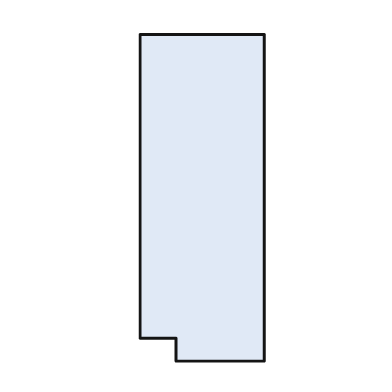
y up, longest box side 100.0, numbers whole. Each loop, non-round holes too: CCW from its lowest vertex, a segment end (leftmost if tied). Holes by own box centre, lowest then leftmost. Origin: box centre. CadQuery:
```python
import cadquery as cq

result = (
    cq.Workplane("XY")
    .moveTo(-8.0, -50.0)
    .lineTo(19.0, -50.0)
    .lineTo(19.0, 50.0)
    .lineTo(-19.0, 50.0)
    .lineTo(-19.0, -43.0)
    .lineTo(-8.0, -43.0)
    .close()
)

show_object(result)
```